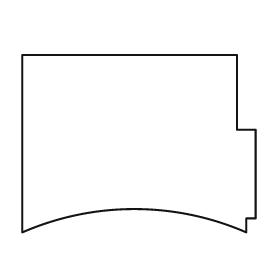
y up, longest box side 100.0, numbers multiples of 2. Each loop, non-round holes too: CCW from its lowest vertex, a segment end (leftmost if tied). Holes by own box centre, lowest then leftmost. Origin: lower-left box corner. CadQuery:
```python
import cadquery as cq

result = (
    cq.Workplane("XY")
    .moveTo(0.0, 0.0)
    .threePointArc((48.0, 10.0), (96.0, 0.0))
    .lineTo(96.0, 6.0)
    .lineTo(100.0, 6.0)
    .lineTo(100.0, 44.0)
    .lineTo(92.0, 44.0)
    .lineTo(92.0, 76.0)
    .lineTo(0.0, 76.0)
    .close()
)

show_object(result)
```